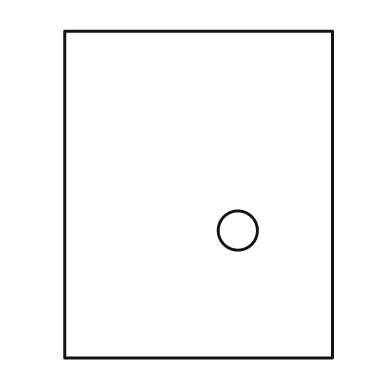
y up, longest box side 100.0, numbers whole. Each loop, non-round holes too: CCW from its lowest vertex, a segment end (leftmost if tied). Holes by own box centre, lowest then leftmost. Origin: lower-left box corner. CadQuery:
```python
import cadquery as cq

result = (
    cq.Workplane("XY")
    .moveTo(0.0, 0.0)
    .lineTo(82.0, 0.0)
    .lineTo(82.0, 100.0)
    .lineTo(0.0, 100.0)
    .close()
    .moveTo(53.0, 39.0)
    .circle(6.0)
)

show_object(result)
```